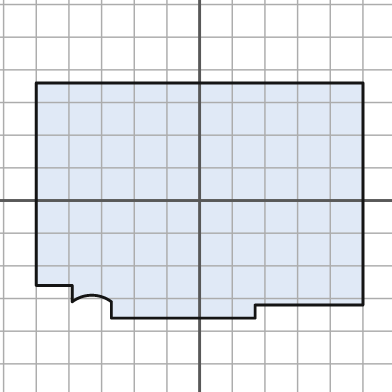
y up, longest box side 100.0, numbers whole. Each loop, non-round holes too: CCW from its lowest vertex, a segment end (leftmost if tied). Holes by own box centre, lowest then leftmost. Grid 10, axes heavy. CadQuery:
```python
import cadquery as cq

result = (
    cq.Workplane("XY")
    .moveTo(-27.0, -36.0)
    .lineTo(17.0, -36.0)
    .lineTo(17.0, -32.0)
    .lineTo(50.0, -32.0)
    .lineTo(50.0, 36.0)
    .lineTo(-50.0, 36.0)
    .lineTo(-50.0, -26.0)
    .lineTo(-39.0, -26.0)
    .lineTo(-39.0, -31.0)
    .threePointArc((-33.0, -29.0), (-27.0, -31.0))
    .close()
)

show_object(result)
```